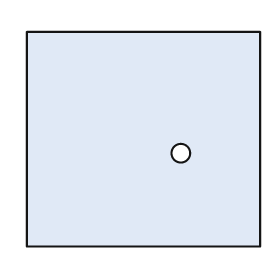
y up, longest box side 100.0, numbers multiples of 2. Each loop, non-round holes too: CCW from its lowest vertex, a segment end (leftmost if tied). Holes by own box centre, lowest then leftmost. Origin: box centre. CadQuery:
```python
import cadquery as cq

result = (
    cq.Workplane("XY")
    .moveTo(-50.0, -46.0)
    .lineTo(50.0, -46.0)
    .lineTo(50.0, 46.0)
    .lineTo(-50.0, 46.0)
    .close()
    .moveTo(16.0, -6.0)
    .circle(4.0)
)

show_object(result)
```